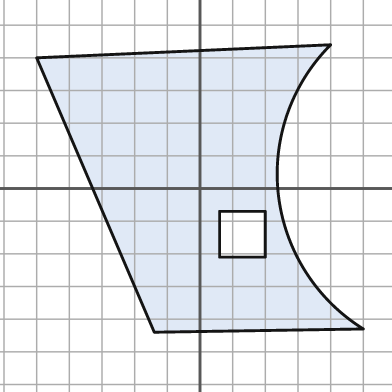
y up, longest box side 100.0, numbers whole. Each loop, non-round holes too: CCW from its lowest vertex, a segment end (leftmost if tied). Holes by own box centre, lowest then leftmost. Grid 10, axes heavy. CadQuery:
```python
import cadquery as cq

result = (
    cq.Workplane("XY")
    .moveTo(-14.0, -44.0)
    .lineTo(50.0, -43.0)
    .threePointArc((24.0, -2.0), (40.0, 44.0))
    .lineTo(-50.0, 40.0)
    .close()
    .moveTo(6.0, -21.0)
    .lineTo(20.0, -21.0)
    .lineTo(20.0, -7.0)
    .lineTo(6.0, -7.0)
    .close()
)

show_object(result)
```